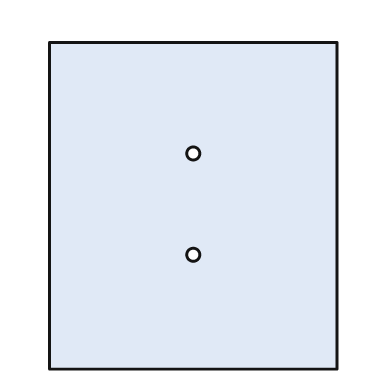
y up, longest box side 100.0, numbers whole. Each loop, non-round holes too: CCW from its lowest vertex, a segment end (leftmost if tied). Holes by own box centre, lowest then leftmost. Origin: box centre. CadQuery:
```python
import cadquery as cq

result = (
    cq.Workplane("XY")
    .moveTo(-44.0, -50.0)
    .lineTo(44.0, -50.0)
    .lineTo(44.0, 50.0)
    .lineTo(-44.0, 50.0)
    .close()
    .moveTo(0.0, -15.0)
    .circle(2.0)
    .moveTo(0.0, 16.0)
    .circle(2.0)
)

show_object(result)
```